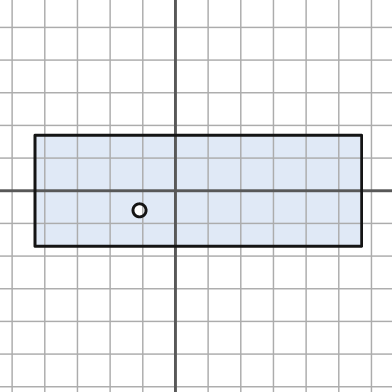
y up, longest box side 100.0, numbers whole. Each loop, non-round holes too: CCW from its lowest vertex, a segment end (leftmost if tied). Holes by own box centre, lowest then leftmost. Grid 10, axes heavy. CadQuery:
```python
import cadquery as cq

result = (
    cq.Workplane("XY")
    .moveTo(-43.0, -17.0)
    .lineTo(57.0, -17.0)
    .lineTo(57.0, 17.0)
    .lineTo(-43.0, 17.0)
    .close()
    .moveTo(-11.0, -6.0)
    .circle(2.0)
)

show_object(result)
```